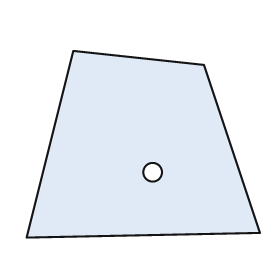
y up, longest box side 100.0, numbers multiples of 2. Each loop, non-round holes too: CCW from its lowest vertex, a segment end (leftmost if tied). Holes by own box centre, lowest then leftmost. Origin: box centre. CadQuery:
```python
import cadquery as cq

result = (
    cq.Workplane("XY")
    .moveTo(-50.0, -40.0)
    .lineTo(50.0, -38.0)
    .lineTo(26.0, 34.0)
    .lineTo(-30.0, 40.0)
    .close()
    .moveTo(4.0, -12.0)
    .circle(4.0)
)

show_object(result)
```